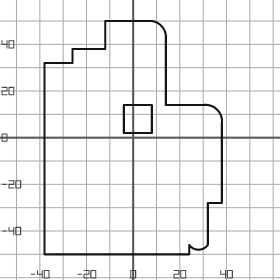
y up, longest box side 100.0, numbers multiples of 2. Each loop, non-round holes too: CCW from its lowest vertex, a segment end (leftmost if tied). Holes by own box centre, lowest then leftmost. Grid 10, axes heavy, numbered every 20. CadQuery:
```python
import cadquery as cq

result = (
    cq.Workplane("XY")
    .moveTo(-38.0, -50.0)
    .lineTo(24.0, -50.0)
    .lineTo(24.0, -46.0)
    .threePointArc((28.0, -48.0), (32.0, -46.0))
    .lineTo(32.0, -28.0)
    .lineTo(38.0, -28.0)
    .lineTo(38.0, 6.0)
    .threePointArc((36.0, 12.0), (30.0, 14.0))
    .lineTo(14.0, 14.0)
    .lineTo(14.0, 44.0)
    .threePointArc((12.0, 48.0), (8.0, 50.0))
    .lineTo(-12.0, 50.0)
    .lineTo(-12.0, 38.0)
    .lineTo(-26.0, 38.0)
    .lineTo(-26.0, 32.0)
    .lineTo(-38.0, 32.0)
    .close()
    .moveTo(-4.0, 2.0)
    .lineTo(8.0, 2.0)
    .lineTo(8.0, 14.0)
    .lineTo(-4.0, 14.0)
    .close()
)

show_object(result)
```